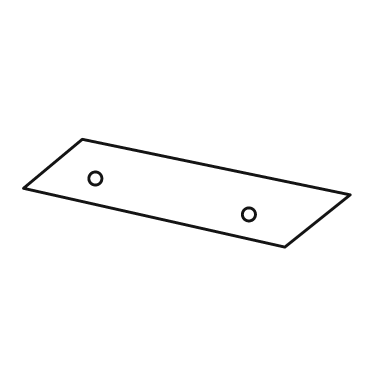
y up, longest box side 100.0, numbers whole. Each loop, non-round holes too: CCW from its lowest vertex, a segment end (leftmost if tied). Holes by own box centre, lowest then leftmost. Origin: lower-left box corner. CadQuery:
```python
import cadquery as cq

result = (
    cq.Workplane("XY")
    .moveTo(80.0, 0.0)
    .lineTo(100.0, 16.0)
    .lineTo(18.0, 33.0)
    .lineTo(0.0, 18.0)
    .close()
    .moveTo(69.0, 10.0)
    .circle(2.0)
    .moveTo(22.0, 21.0)
    .circle(2.0)
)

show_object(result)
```